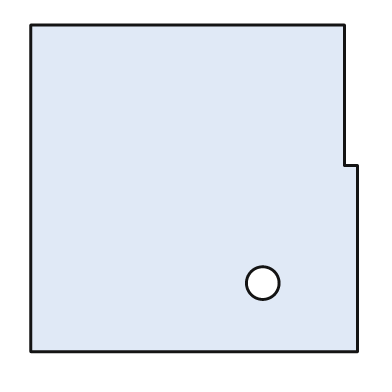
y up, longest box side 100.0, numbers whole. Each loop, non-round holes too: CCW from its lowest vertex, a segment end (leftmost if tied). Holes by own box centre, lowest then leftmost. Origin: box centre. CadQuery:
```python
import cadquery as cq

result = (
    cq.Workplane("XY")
    .moveTo(-50.0, -50.0)
    .lineTo(50.0, -50.0)
    .lineTo(50.0, 7.0)
    .lineTo(46.0, 7.0)
    .lineTo(46.0, 50.0)
    .lineTo(-50.0, 50.0)
    .close()
    .moveTo(21.0, -29.0)
    .circle(5.0)
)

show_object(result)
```